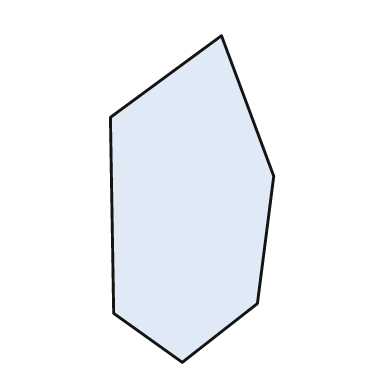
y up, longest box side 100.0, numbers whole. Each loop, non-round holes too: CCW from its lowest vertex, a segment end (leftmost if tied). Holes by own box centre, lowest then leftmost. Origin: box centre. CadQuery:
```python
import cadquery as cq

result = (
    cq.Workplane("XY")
    .moveTo(-3.0, -50.0)
    .lineTo(20.0, -32.0)
    .lineTo(25.0, 7.0)
    .lineTo(9.0, 50.0)
    .lineTo(-25.0, 25.0)
    .lineTo(-24.0, -35.0)
    .close()
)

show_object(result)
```